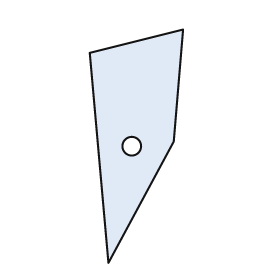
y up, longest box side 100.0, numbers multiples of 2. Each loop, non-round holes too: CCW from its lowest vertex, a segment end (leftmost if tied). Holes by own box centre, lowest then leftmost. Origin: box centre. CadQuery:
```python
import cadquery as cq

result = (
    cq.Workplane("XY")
    .moveTo(-12.0, -50.0)
    .lineTo(16.0, 2.0)
    .lineTo(20.0, 50.0)
    .lineTo(-20.0, 40.0)
    .close()
    .moveTo(-2.0, 0.0)
    .circle(4.0)
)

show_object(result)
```